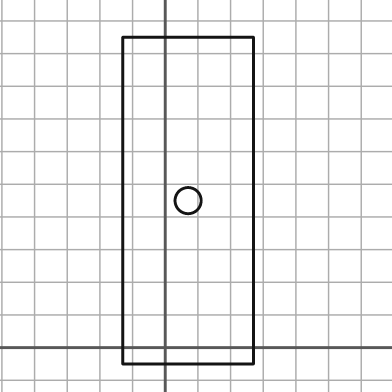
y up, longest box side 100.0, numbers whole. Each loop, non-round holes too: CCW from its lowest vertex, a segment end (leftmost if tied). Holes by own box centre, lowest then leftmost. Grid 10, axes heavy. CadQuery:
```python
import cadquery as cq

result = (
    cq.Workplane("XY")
    .moveTo(-13.0, -5.0)
    .lineTo(27.0, -5.0)
    .lineTo(27.0, 95.0)
    .lineTo(-13.0, 95.0)
    .close()
    .moveTo(7.0, 45.0)
    .circle(4.0)
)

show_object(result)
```